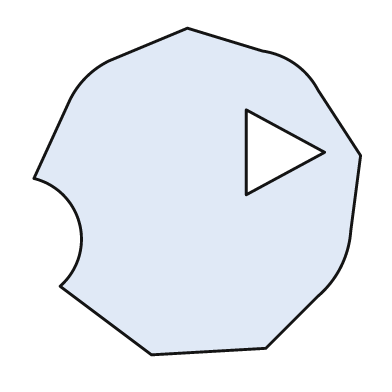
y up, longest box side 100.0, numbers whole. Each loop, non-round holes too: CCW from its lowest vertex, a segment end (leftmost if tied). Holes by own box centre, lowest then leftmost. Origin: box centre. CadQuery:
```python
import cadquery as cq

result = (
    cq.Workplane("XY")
    .moveTo(-14.0, -50.0)
    .lineTo(21.0, -48.0)
    .lineTo(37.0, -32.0)
    .threePointArc((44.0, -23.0), (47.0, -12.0))
    .lineTo(50.0, 11.0)
    .lineTo(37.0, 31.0)
    .threePointArc((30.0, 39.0), (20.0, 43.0))
    .lineTo(-3.0, 50.0)
    .lineTo(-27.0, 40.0)
    .threePointArc((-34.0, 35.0), (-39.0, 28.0))
    .lineTo(-50.0, 4.0)
    .threePointArc((-36.0, -10.0), (-42.0, -29.0))
    .close()
    .moveTo(15.0, -1.0)
    .lineTo(39.0, 12.0)
    .lineTo(15.0, 25.0)
    .close()
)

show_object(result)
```